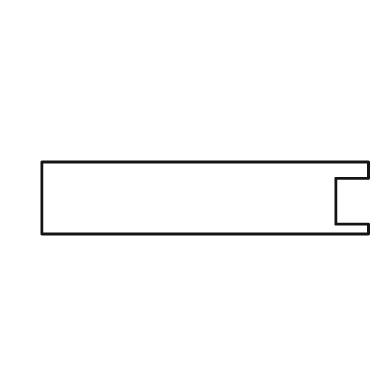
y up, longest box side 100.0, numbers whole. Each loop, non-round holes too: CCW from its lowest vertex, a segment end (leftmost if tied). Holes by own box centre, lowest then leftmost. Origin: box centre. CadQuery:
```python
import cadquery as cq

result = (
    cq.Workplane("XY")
    .moveTo(-50.0, -11.0)
    .lineTo(50.0, -11.0)
    .lineTo(50.0, -8.0)
    .lineTo(40.0, -8.0)
    .lineTo(40.0, 6.0)
    .lineTo(50.0, 6.0)
    .lineTo(50.0, 11.0)
    .lineTo(-50.0, 11.0)
    .close()
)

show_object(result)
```